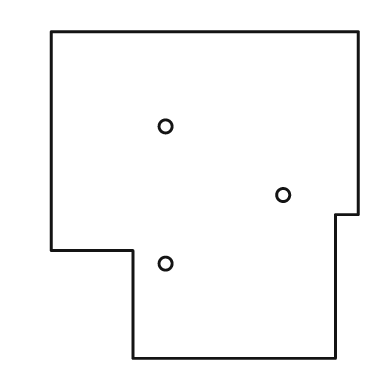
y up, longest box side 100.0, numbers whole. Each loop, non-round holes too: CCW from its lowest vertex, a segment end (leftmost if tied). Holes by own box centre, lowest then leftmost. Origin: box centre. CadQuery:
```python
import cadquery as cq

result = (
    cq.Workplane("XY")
    .moveTo(-22.0, -50.0)
    .lineTo(40.0, -50.0)
    .lineTo(40.0, -6.0)
    .lineTo(47.0, -6.0)
    .lineTo(47.0, 50.0)
    .lineTo(-47.0, 50.0)
    .lineTo(-47.0, -17.0)
    .lineTo(-22.0, -17.0)
    .close()
    .moveTo(-12.0, -21.0)
    .circle(2.0)
    .moveTo(24.0, 0.0)
    .circle(2.0)
    .moveTo(-12.0, 21.0)
    .circle(2.0)
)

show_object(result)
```